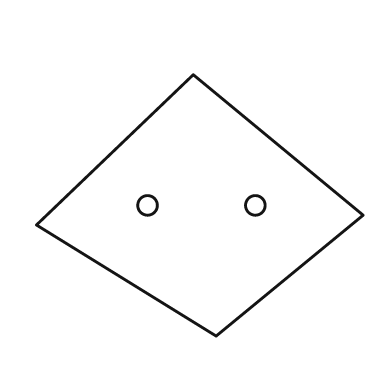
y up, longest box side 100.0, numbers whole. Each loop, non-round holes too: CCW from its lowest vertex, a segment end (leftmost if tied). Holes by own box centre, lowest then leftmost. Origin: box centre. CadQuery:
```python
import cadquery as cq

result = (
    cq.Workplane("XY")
    .moveTo(5.0, -40.0)
    .lineTo(50.0, -3.0)
    .lineTo(-2.0, 40.0)
    .lineTo(-50.0, -6.0)
    .close()
    .moveTo(-16.0, 0.0)
    .circle(3.0)
    .moveTo(17.0, 0.0)
    .circle(3.0)
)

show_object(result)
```